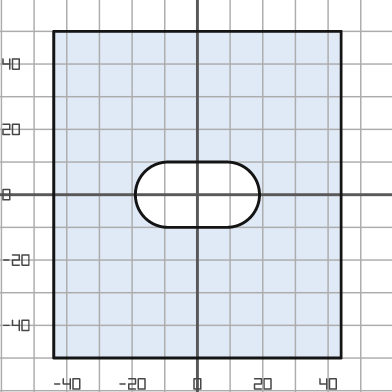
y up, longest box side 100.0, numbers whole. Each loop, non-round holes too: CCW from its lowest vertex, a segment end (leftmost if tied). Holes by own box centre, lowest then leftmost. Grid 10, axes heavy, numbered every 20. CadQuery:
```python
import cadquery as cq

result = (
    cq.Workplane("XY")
    .moveTo(-44.0, -50.0)
    .lineTo(44.0, -50.0)
    .lineTo(44.0, 50.0)
    .lineTo(-44.0, 50.0)
    .close()
    .moveTo(-9.0, -10.0)
    .lineTo(9.0, -10.0)
    .threePointArc((19.0, 0.0), (9.0, 10.0))
    .lineTo(-9.0, 10.0)
    .threePointArc((-19.0, 0.0), (-9.0, -10.0))
    .close()
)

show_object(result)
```